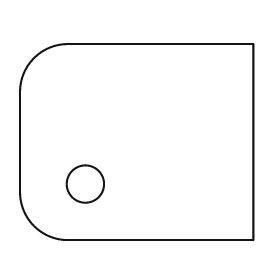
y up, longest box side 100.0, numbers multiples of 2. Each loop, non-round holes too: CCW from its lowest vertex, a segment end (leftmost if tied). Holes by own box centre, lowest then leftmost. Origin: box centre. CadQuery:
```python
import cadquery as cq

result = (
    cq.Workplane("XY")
    .moveTo(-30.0, -42.0)
    .lineTo(50.0, -42.0)
    .lineTo(50.0, 42.0)
    .lineTo(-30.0, 42.0)
    .threePointArc((-44.0, 36.0), (-50.0, 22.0))
    .lineTo(-50.0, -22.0)
    .threePointArc((-44.0, -36.0), (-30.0, -42.0))
    .close()
    .moveTo(-22.0, -18.0)
    .circle(8.0)
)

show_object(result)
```